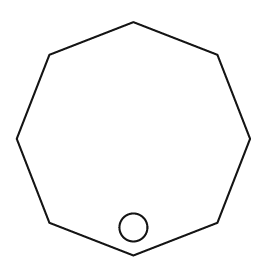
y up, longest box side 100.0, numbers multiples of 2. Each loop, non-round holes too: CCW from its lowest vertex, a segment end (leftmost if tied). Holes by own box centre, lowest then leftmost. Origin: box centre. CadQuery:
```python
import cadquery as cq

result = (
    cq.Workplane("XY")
    .moveTo(0.0, -50.0)
    .lineTo(36.0, -36.0)
    .lineTo(50.0, 0.0)
    .lineTo(36.0, 36.0)
    .lineTo(0.0, 50.0)
    .lineTo(-36.0, 36.0)
    .lineTo(-50.0, 0.0)
    .lineTo(-36.0, -36.0)
    .close()
    .moveTo(0.0, -38.0)
    .circle(6.0)
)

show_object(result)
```